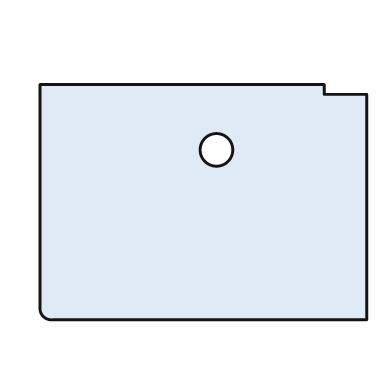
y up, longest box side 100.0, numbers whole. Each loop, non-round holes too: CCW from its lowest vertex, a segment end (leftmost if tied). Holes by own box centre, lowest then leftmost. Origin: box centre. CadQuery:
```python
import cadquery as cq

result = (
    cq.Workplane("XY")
    .moveTo(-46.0, -36.0)
    .lineTo(50.0, -36.0)
    .lineTo(50.0, 33.0)
    .lineTo(37.0, 33.0)
    .lineTo(37.0, 36.0)
    .lineTo(-50.0, 36.0)
    .lineTo(-50.0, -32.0)
    .threePointArc((-49.0, -35.0), (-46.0, -36.0))
    .close()
    .moveTo(4.0, 16.0)
    .circle(5.0)
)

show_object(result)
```